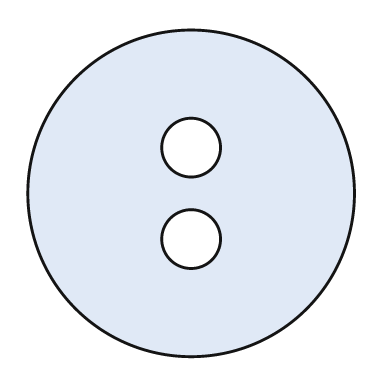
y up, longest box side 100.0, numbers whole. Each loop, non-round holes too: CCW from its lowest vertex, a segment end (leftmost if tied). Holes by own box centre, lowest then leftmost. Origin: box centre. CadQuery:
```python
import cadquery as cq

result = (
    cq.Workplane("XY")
    .moveTo(0.0, 0.0)
    .circle(50.0)
    .moveTo(0.0, -14.0)
    .circle(9.0)
    .moveTo(0.0, 14.0)
    .circle(9.0)
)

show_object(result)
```